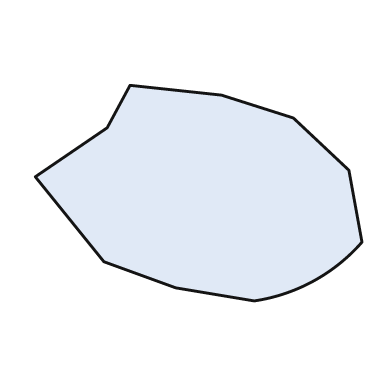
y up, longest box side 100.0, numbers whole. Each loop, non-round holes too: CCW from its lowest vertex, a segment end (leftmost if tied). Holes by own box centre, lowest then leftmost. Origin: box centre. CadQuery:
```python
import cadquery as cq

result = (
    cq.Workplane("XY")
    .moveTo(17.0, -33.0)
    .threePointArc((35.0, -27.0), (50.0, -15.0))
    .lineTo(46.0, 7.0)
    .lineTo(29.0, 23.0)
    .lineTo(7.0, 30.0)
    .lineTo(-21.0, 33.0)
    .lineTo(-28.0, 20.0)
    .lineTo(-50.0, 5.0)
    .lineTo(-29.0, -21.0)
    .lineTo(-7.0, -29.0)
    .close()
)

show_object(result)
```